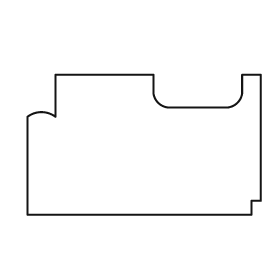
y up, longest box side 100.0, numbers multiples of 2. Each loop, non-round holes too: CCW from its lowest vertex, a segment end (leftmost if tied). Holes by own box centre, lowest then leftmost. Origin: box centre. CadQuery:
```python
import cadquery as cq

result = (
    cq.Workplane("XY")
    .moveTo(-50.0, -30.0)
    .lineTo(46.0, -30.0)
    .lineTo(46.0, -24.0)
    .lineTo(50.0, -24.0)
    .lineTo(50.0, 30.0)
    .lineTo(42.0, 30.0)
    .lineTo(42.0, 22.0)
    .threePointArc((40.0, 18.0), (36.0, 16.0))
    .lineTo(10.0, 16.0)
    .threePointArc((6.0, 18.0), (4.0, 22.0))
    .lineTo(4.0, 30.0)
    .lineTo(-38.0, 30.0)
    .lineTo(-38.0, 12.0)
    .threePointArc((-44.0, 14.0), (-50.0, 12.0))
    .close()
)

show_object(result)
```